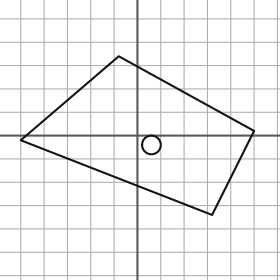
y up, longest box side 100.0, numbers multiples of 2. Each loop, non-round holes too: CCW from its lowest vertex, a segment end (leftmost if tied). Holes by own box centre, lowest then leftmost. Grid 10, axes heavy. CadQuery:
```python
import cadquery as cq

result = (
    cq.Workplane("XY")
    .moveTo(32.0, -34.0)
    .lineTo(50.0, 2.0)
    .lineTo(-8.0, 34.0)
    .lineTo(-50.0, -2.0)
    .close()
    .moveTo(6.0, -4.0)
    .circle(4.0)
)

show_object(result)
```